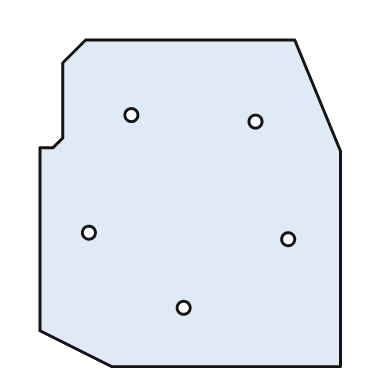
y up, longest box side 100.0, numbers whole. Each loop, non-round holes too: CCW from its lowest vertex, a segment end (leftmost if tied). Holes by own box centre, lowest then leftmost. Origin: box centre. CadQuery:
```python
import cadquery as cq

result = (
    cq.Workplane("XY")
    .moveTo(-24.0, -50.0)
    .lineTo(46.0, -50.0)
    .lineTo(46.0, 16.0)
    .lineTo(32.0, 50.0)
    .lineTo(-32.0, 50.0)
    .lineTo(-39.0, 43.0)
    .lineTo(-39.0, 20.0)
    .lineTo(-42.0, 17.0)
    .lineTo(-46.0, 17.0)
    .lineTo(-46.0, -39.0)
    .close()
    .moveTo(-2.0, -32.0)
    .circle(2.0)
    .moveTo(30.0, -11.0)
    .circle(2.0)
    .moveTo(-31.0, -9.0)
    .circle(2.0)
    .moveTo(20.0, 25.0)
    .circle(2.0)
    .moveTo(-18.0, 27.0)
    .circle(2.0)
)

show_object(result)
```